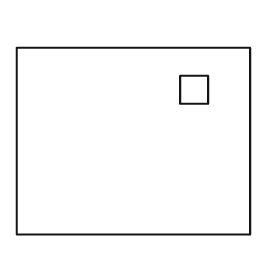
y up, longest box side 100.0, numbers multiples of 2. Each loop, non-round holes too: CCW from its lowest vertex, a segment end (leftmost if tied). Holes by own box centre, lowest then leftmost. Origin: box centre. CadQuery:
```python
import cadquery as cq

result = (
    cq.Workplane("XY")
    .moveTo(-50.0, -40.0)
    .lineTo(50.0, -40.0)
    .lineTo(50.0, 40.0)
    .lineTo(-50.0, 40.0)
    .close()
    .moveTo(20.0, 16.0)
    .lineTo(32.0, 16.0)
    .lineTo(32.0, 28.0)
    .lineTo(20.0, 28.0)
    .close()
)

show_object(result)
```